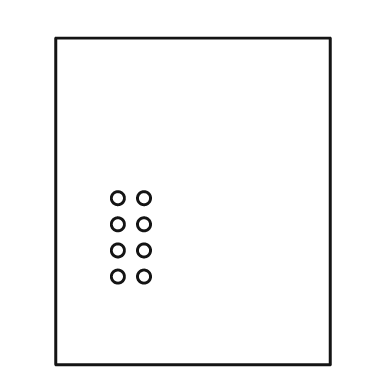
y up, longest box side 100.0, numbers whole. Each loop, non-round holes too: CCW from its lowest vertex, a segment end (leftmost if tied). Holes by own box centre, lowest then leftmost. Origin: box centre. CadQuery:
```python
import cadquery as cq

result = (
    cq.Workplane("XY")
    .moveTo(-42.0, -50.0)
    .lineTo(42.0, -50.0)
    .lineTo(42.0, 50.0)
    .lineTo(-42.0, 50.0)
    .close()
    .moveTo(-23.0, -23.0)
    .circle(2.0)
    .moveTo(-15.0, -23.0)
    .circle(2.0)
    .moveTo(-23.0, -15.0)
    .circle(2.0)
    .moveTo(-15.0, -15.0)
    .circle(2.0)
    .moveTo(-23.0, -7.0)
    .circle(2.0)
    .moveTo(-15.0, -7.0)
    .circle(2.0)
    .moveTo(-23.0, 1.0)
    .circle(2.0)
    .moveTo(-15.0, 1.0)
    .circle(2.0)
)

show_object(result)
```